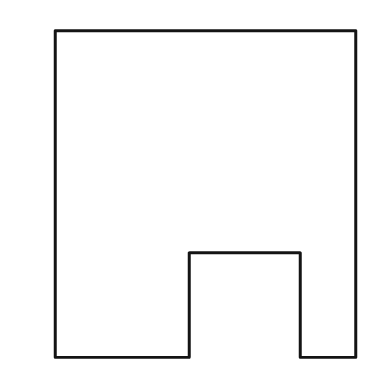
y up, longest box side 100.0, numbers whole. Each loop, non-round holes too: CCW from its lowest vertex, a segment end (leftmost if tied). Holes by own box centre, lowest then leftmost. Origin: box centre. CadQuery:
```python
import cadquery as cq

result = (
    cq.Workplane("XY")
    .moveTo(-46.0, -50.0)
    .lineTo(-5.0, -50.0)
    .lineTo(-5.0, -18.0)
    .lineTo(29.0, -18.0)
    .lineTo(29.0, -50.0)
    .lineTo(46.0, -50.0)
    .lineTo(46.0, 50.0)
    .lineTo(-46.0, 50.0)
    .close()
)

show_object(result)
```